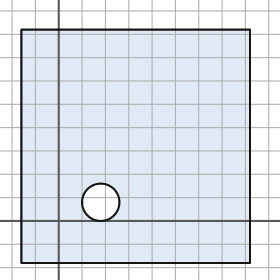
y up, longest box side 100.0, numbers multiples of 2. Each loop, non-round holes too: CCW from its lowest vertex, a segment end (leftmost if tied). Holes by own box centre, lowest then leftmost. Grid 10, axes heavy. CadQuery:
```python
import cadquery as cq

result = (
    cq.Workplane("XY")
    .moveTo(-16.0, -18.0)
    .lineTo(82.0, -18.0)
    .lineTo(82.0, 82.0)
    .lineTo(-16.0, 82.0)
    .close()
    .moveTo(18.0, 8.0)
    .circle(8.0)
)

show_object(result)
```